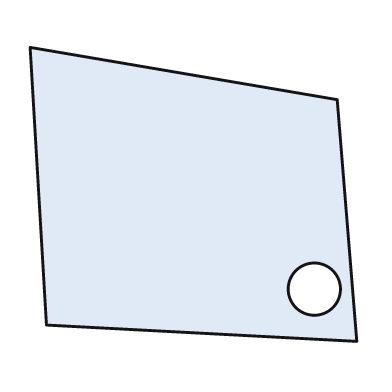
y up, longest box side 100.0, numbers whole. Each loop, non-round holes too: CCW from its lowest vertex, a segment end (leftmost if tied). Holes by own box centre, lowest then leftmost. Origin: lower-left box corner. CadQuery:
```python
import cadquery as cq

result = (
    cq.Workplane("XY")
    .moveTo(100.0, 0.0)
    .lineTo(94.0, 74.0)
    .lineTo(0.0, 90.0)
    .lineTo(5.0, 5.0)
    .close()
    .moveTo(87.0, 16.0)
    .circle(8.0)
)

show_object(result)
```